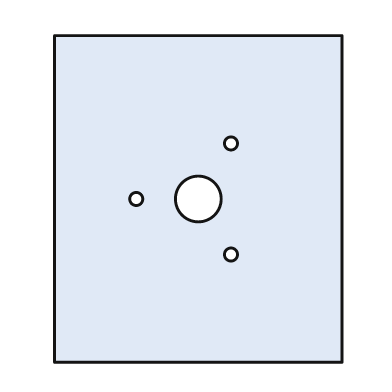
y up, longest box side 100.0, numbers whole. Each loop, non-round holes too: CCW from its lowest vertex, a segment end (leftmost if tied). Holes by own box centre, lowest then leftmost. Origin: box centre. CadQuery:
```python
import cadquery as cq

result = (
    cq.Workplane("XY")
    .moveTo(-44.0, -50.0)
    .lineTo(44.0, -50.0)
    .lineTo(44.0, 50.0)
    .lineTo(-44.0, 50.0)
    .close()
    .moveTo(10.0, -17.0)
    .circle(2.0)
    .moveTo(-19.0, 0.0)
    .circle(2.0)
    .moveTo(0.0, 0.0)
    .circle(7.0)
    .moveTo(10.0, 17.0)
    .circle(2.0)
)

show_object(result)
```